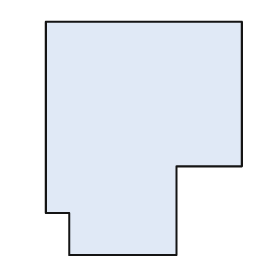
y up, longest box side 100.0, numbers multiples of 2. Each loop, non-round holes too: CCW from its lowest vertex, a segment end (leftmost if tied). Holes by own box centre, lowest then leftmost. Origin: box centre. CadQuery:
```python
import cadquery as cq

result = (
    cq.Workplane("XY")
    .moveTo(-32.0, -50.0)
    .lineTo(14.0, -50.0)
    .lineTo(14.0, -12.0)
    .lineTo(42.0, -12.0)
    .lineTo(42.0, 50.0)
    .lineTo(-42.0, 50.0)
    .lineTo(-42.0, -32.0)
    .lineTo(-32.0, -32.0)
    .close()
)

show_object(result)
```